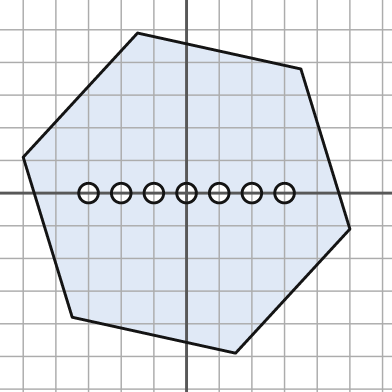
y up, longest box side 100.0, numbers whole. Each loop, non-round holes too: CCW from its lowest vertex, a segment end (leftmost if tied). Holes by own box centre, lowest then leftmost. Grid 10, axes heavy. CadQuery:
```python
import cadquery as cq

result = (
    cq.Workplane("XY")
    .moveTo(15.0, -49.0)
    .lineTo(50.0, -11.0)
    .lineTo(35.0, 38.0)
    .lineTo(-15.0, 49.0)
    .lineTo(-50.0, 11.0)
    .lineTo(-35.0, -38.0)
    .close()
    .moveTo(-30.0, 0.0)
    .circle(3.0)
    .moveTo(-20.0, 0.0)
    .circle(3.0)
    .moveTo(-10.0, 0.0)
    .circle(3.0)
    .moveTo(0.0, 0.0)
    .circle(3.0)
    .moveTo(10.0, 0.0)
    .circle(3.0)
    .moveTo(20.0, 0.0)
    .circle(3.0)
    .moveTo(30.0, 0.0)
    .circle(3.0)
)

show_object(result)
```